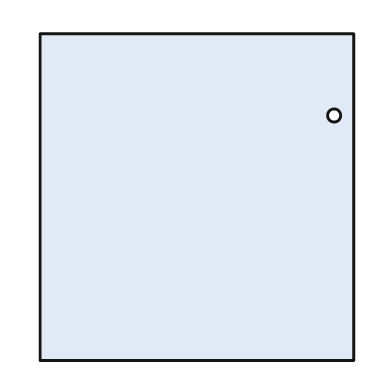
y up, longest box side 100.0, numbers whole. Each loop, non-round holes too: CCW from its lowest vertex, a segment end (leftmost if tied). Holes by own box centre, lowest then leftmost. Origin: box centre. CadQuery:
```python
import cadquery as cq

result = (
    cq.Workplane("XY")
    .moveTo(-48.0, -50.0)
    .lineTo(48.0, -50.0)
    .lineTo(48.0, 50.0)
    .lineTo(-48.0, 50.0)
    .close()
    .moveTo(42.0, 25.0)
    .circle(2.0)
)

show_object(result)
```